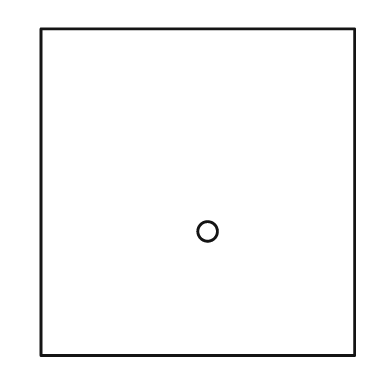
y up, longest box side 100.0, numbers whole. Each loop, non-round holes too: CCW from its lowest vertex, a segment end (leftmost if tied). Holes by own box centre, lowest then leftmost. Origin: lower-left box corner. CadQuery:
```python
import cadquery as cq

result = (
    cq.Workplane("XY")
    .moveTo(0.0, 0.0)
    .lineTo(96.0, 0.0)
    .lineTo(96.0, 100.0)
    .lineTo(0.0, 100.0)
    .close()
    .moveTo(51.0, 38.0)
    .circle(3.0)
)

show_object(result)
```